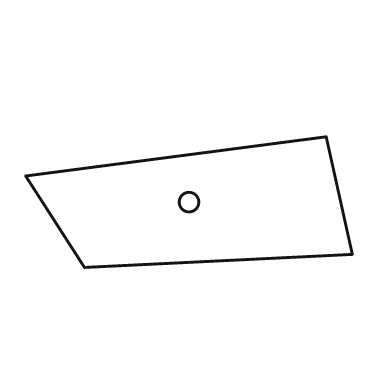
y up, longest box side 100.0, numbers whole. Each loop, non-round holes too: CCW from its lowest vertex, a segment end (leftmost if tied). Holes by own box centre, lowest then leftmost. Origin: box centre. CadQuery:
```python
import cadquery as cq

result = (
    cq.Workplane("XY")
    .moveTo(-32.0, -20.0)
    .lineTo(50.0, -16.0)
    .lineTo(42.0, 20.0)
    .lineTo(-50.0, 8.0)
    .close()
    .moveTo(0.0, 0.0)
    .circle(3.0)
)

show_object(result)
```